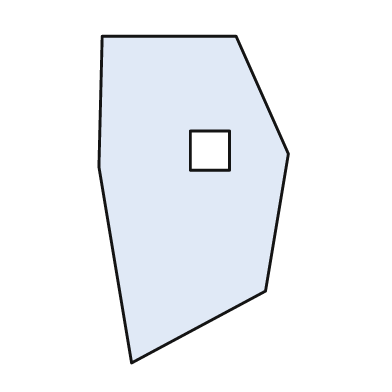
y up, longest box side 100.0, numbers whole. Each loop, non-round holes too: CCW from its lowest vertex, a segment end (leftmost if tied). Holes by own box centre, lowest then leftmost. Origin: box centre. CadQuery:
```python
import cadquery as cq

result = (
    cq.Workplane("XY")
    .moveTo(-19.0, -50.0)
    .lineTo(22.0, -28.0)
    .lineTo(29.0, 14.0)
    .lineTo(13.0, 50.0)
    .lineTo(-28.0, 50.0)
    .lineTo(-29.0, 10.0)
    .close()
    .moveTo(-1.0, 9.0)
    .lineTo(11.0, 9.0)
    .lineTo(11.0, 21.0)
    .lineTo(-1.0, 21.0)
    .close()
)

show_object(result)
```